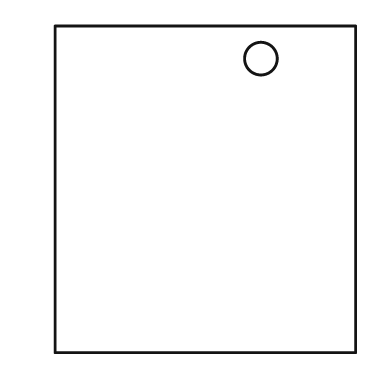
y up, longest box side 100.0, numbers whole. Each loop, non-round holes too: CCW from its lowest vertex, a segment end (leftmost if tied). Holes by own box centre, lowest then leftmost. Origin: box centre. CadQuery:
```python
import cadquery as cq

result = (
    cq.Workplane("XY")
    .moveTo(-46.0, -50.0)
    .lineTo(46.0, -50.0)
    .lineTo(46.0, 50.0)
    .lineTo(-46.0, 50.0)
    .close()
    .moveTo(17.0, 40.0)
    .circle(5.0)
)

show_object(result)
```